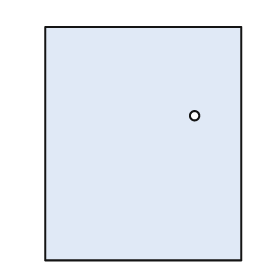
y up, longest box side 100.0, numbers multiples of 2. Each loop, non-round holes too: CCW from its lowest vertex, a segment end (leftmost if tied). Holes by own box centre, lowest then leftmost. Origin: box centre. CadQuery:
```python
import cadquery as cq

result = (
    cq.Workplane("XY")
    .moveTo(-42.0, -50.0)
    .lineTo(42.0, -50.0)
    .lineTo(42.0, 50.0)
    .lineTo(-42.0, 50.0)
    .close()
    .moveTo(22.0, 12.0)
    .circle(2.0)
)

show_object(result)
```